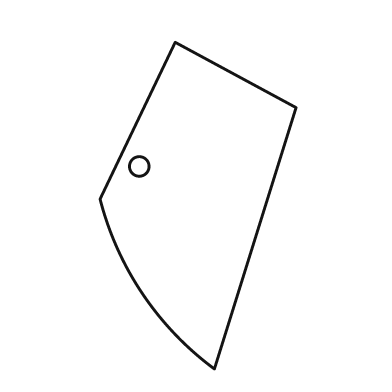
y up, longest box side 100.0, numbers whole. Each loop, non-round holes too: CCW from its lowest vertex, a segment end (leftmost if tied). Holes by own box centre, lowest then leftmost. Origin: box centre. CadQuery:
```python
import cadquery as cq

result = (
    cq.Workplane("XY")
    .moveTo(5.0, -50.0)
    .lineTo(30.0, 30.0)
    .lineTo(-7.0, 50.0)
    .lineTo(-30.0, 2.0)
    .threePointArc((-17.0, -27.0), (5.0, -50.0))
    .close()
    .moveTo(-18.0, 12.0)
    .circle(3.0)
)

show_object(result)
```